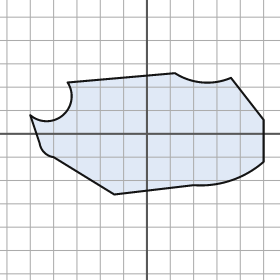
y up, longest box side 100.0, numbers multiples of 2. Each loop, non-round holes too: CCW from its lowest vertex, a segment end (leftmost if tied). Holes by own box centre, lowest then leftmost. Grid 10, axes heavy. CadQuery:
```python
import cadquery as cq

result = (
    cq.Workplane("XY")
    .moveTo(-14.0, -26.0)
    .lineTo(20.0, -22.0)
    .threePointArc((36.0, -20.0), (50.0, -12.0))
    .lineTo(50.0, 6.0)
    .lineTo(36.0, 24.0)
    .threePointArc((24.0, 22.0), (12.0, 26.0))
    .lineTo(-34.0, 22.0)
    .threePointArc((-36.0, 8.0), (-50.0, 8.0))
    .lineTo(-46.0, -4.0)
    .threePointArc((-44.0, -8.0), (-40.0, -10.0))
    .close()
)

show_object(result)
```